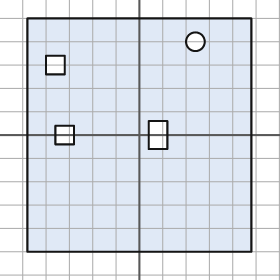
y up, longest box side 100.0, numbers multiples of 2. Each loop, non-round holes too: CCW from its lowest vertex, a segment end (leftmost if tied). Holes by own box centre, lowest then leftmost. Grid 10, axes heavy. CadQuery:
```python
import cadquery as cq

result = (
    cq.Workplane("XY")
    .moveTo(-48.0, -50.0)
    .lineTo(48.0, -50.0)
    .lineTo(48.0, 50.0)
    .lineTo(-48.0, 50.0)
    .close()
    .moveTo(-36.0, -4.0)
    .lineTo(-28.0, -4.0)
    .lineTo(-28.0, 4.0)
    .lineTo(-36.0, 4.0)
    .close()
    .moveTo(4.0, -6.0)
    .lineTo(12.0, -6.0)
    .lineTo(12.0, 6.0)
    .lineTo(4.0, 6.0)
    .close()
    .moveTo(-40.0, 26.0)
    .lineTo(-32.0, 26.0)
    .lineTo(-32.0, 34.0)
    .lineTo(-40.0, 34.0)
    .close()
    .moveTo(24.0, 40.0)
    .circle(4.0)
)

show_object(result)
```